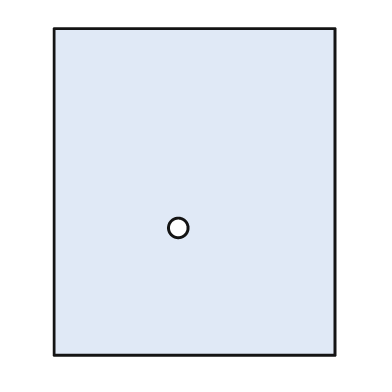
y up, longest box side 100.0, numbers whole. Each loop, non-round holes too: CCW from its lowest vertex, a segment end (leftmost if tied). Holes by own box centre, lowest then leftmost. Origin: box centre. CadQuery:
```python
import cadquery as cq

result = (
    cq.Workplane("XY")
    .moveTo(-43.0, -50.0)
    .lineTo(43.0, -50.0)
    .lineTo(43.0, 50.0)
    .lineTo(-43.0, 50.0)
    .close()
    .moveTo(-5.0, -11.0)
    .circle(3.0)
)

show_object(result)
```